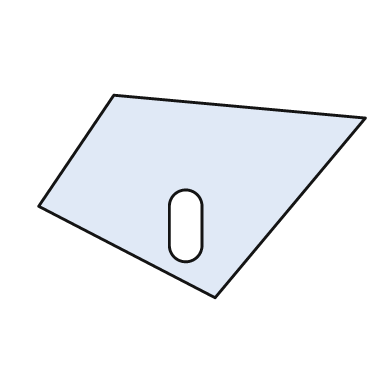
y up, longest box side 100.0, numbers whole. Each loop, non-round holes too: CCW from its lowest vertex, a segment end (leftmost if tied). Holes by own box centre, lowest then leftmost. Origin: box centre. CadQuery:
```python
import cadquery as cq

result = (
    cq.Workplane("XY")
    .moveTo(4.0, -31.0)
    .lineTo(50.0, 24.0)
    .lineTo(-27.0, 31.0)
    .lineTo(-50.0, -3.0)
    .close()
    .moveTo(-10.0, -15.0)
    .threePointArc((-5.0, -20.0), (0.0, -15.0))
    .lineTo(0.0, -3.0)
    .threePointArc((-5.0, 2.0), (-10.0, -3.0))
    .close()
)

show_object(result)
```